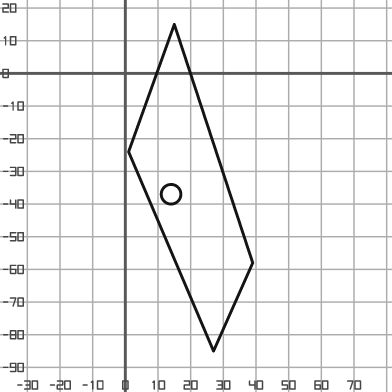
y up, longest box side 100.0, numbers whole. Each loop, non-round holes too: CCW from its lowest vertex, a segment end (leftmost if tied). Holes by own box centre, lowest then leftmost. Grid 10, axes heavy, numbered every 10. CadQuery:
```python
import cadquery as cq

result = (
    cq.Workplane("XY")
    .moveTo(27.0, -85.0)
    .lineTo(39.0, -58.0)
    .lineTo(15.0, 15.0)
    .lineTo(1.0, -24.0)
    .close()
    .moveTo(14.0, -37.0)
    .circle(3.0)
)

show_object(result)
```